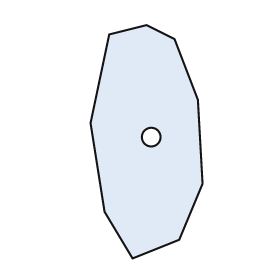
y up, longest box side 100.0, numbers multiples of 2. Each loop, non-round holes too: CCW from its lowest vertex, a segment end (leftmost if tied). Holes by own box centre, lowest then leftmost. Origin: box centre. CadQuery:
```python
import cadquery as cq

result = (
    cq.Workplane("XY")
    .moveTo(-6.0, -50.0)
    .lineTo(14.0, -42.0)
    .lineTo(24.0, -18.0)
    .lineTo(22.0, 18.0)
    .lineTo(12.0, 44.0)
    .lineTo(0.0, 50.0)
    .lineTo(-16.0, 46.0)
    .lineTo(-24.0, 8.0)
    .lineTo(-18.0, -30.0)
    .close()
    .moveTo(2.0, 2.0)
    .circle(4.0)
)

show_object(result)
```